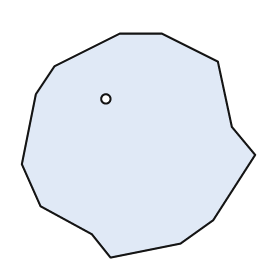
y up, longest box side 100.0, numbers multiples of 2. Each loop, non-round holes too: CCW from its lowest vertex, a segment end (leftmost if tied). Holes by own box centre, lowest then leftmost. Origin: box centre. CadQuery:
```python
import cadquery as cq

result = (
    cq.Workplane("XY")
    .moveTo(-12.0, -48.0)
    .lineTo(18.0, -42.0)
    .lineTo(32.0, -32.0)
    .lineTo(50.0, -4.0)
    .lineTo(40.0, 8.0)
    .lineTo(34.0, 36.0)
    .lineTo(10.0, 48.0)
    .lineTo(-8.0, 48.0)
    .lineTo(-36.0, 34.0)
    .lineTo(-44.0, 22.0)
    .lineTo(-50.0, -8.0)
    .lineTo(-42.0, -26.0)
    .lineTo(-20.0, -38.0)
    .close()
    .moveTo(-14.0, 20.0)
    .circle(2.0)
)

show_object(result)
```